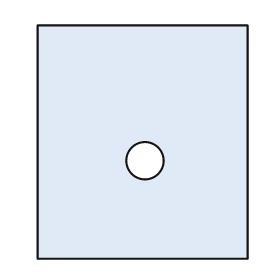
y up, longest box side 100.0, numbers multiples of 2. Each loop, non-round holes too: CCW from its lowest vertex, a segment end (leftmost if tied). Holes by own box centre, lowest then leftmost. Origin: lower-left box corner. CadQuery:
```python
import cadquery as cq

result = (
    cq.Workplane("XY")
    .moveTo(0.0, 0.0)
    .lineTo(90.0, 0.0)
    .lineTo(90.0, 100.0)
    .lineTo(0.0, 100.0)
    .close()
    .moveTo(46.0, 42.0)
    .circle(8.0)
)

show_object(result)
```